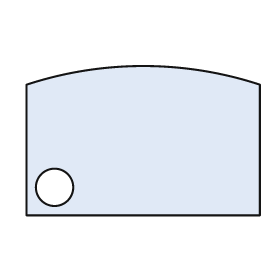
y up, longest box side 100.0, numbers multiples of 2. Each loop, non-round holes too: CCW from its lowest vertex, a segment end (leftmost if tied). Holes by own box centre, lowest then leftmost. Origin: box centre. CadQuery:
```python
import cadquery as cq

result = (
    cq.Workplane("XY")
    .moveTo(-50.0, -32.0)
    .lineTo(50.0, -32.0)
    .lineTo(50.0, 24.0)
    .threePointArc((0.0, 32.0), (-50.0, 24.0))
    .close()
    .moveTo(-38.0, -20.0)
    .circle(8.0)
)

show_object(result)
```